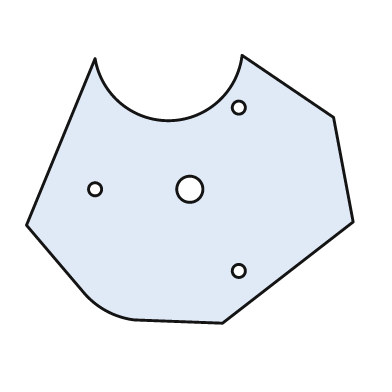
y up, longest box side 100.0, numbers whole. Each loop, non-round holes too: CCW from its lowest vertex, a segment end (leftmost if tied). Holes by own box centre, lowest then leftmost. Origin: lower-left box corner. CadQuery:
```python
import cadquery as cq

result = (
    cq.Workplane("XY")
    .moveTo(60.0, 0.0)
    .lineTo(100.0, 31.0)
    .lineTo(94.0, 63.0)
    .lineTo(66.0, 82.0)
    .threePointArc((44.0, 62.0), (21.0, 81.0))
    .lineTo(0.0, 30.0)
    .lineTo(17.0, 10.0)
    .threePointArc((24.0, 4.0), (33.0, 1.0))
    .close()
    .moveTo(65.0, 16.0)
    .circle(2.0)
    .moveTo(21.0, 41.0)
    .circle(2.0)
    .moveTo(50.0, 41.0)
    .circle(4.0)
    .moveTo(65.0, 66.0)
    .circle(2.0)
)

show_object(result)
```